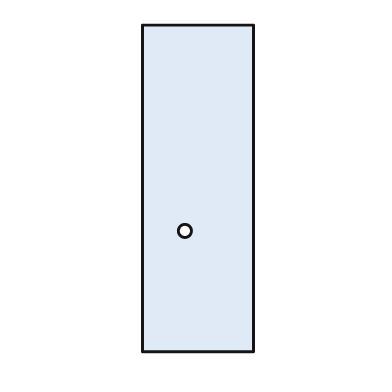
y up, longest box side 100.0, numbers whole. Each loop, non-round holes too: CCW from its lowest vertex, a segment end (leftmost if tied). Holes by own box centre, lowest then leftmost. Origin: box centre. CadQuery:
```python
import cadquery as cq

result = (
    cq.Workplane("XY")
    .moveTo(-17.0, -50.0)
    .lineTo(17.0, -50.0)
    .lineTo(17.0, 50.0)
    .lineTo(-17.0, 50.0)
    .close()
    .moveTo(-4.0, -13.0)
    .circle(2.0)
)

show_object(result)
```